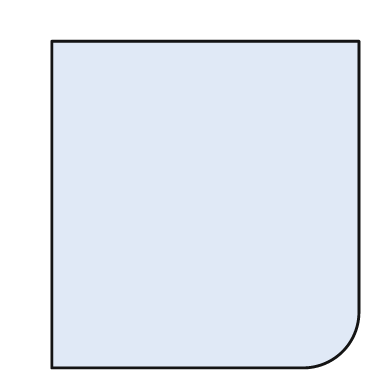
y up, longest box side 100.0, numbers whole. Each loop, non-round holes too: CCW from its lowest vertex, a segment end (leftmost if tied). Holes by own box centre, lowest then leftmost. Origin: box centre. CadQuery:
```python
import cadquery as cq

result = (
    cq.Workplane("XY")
    .moveTo(-47.0, -50.0)
    .lineTo(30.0, -50.0)
    .threePointArc((42.0, -45.0), (47.0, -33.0))
    .lineTo(47.0, 50.0)
    .lineTo(-47.0, 50.0)
    .close()
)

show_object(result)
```